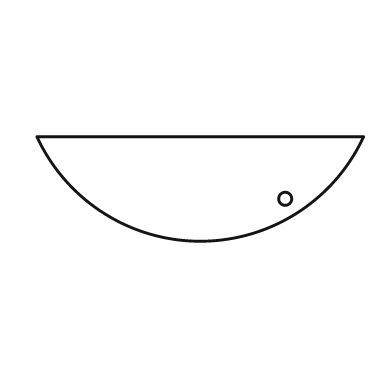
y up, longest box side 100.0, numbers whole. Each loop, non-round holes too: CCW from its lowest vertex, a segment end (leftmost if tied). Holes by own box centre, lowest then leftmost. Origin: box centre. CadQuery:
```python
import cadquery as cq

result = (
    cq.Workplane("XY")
    .moveTo(-50.0, 16.0)
    .threePointArc((0.0, -16.0), (50.0, 16.0))
    .close()
    .moveTo(26.0, -3.0)
    .circle(2.0)
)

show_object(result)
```